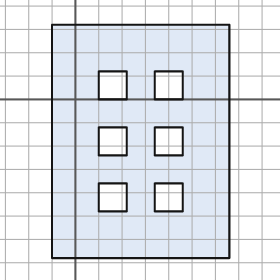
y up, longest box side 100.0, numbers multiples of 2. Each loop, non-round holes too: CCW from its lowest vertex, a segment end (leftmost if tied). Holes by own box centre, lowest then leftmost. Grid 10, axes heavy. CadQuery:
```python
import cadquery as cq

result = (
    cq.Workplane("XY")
    .moveTo(-10.0, -68.0)
    .lineTo(66.0, -68.0)
    .lineTo(66.0, 32.0)
    .lineTo(-10.0, 32.0)
    .close()
    .moveTo(10.0, -48.0)
    .lineTo(22.0, -48.0)
    .lineTo(22.0, -36.0)
    .lineTo(10.0, -36.0)
    .close()
    .moveTo(34.0, -48.0)
    .lineTo(46.0, -48.0)
    .lineTo(46.0, -36.0)
    .lineTo(34.0, -36.0)
    .close()
    .moveTo(10.0, -24.0)
    .lineTo(22.0, -24.0)
    .lineTo(22.0, -12.0)
    .lineTo(10.0, -12.0)
    .close()
    .moveTo(34.0, -24.0)
    .lineTo(46.0, -24.0)
    .lineTo(46.0, -12.0)
    .lineTo(34.0, -12.0)
    .close()
    .moveTo(10.0, 0.0)
    .lineTo(22.0, 0.0)
    .lineTo(22.0, 12.0)
    .lineTo(10.0, 12.0)
    .close()
    .moveTo(34.0, 0.0)
    .lineTo(46.0, 0.0)
    .lineTo(46.0, 12.0)
    .lineTo(34.0, 12.0)
    .close()
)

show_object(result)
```